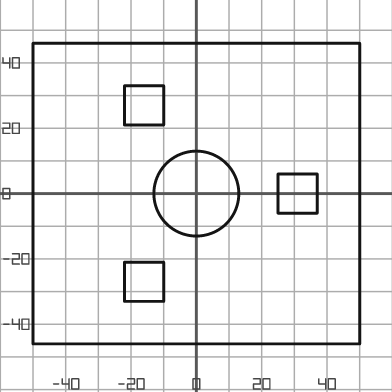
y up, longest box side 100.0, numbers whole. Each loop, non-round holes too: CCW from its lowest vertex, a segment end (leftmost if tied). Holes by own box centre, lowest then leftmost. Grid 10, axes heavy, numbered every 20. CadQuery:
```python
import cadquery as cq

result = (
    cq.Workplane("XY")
    .moveTo(-50.0, -46.0)
    .lineTo(50.0, -46.0)
    .lineTo(50.0, 46.0)
    .lineTo(-50.0, 46.0)
    .close()
    .moveTo(-22.0, -33.0)
    .lineTo(-10.0, -33.0)
    .lineTo(-10.0, -21.0)
    .lineTo(-22.0, -21.0)
    .close()
    .moveTo(0.0, 0.0)
    .circle(13.0)
    .moveTo(25.0, -6.0)
    .lineTo(37.0, -6.0)
    .lineTo(37.0, 6.0)
    .lineTo(25.0, 6.0)
    .close()
    .moveTo(-22.0, 21.0)
    .lineTo(-10.0, 21.0)
    .lineTo(-10.0, 33.0)
    .lineTo(-22.0, 33.0)
    .close()
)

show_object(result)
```